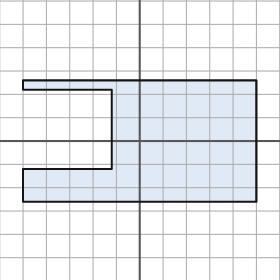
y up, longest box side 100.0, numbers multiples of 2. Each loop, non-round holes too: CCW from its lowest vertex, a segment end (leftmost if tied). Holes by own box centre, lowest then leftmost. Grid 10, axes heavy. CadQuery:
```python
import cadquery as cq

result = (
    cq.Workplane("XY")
    .moveTo(-50.0, -26.0)
    .lineTo(50.0, -26.0)
    .lineTo(50.0, 26.0)
    .lineTo(-50.0, 26.0)
    .lineTo(-50.0, 22.0)
    .lineTo(-12.0, 22.0)
    .lineTo(-12.0, -12.0)
    .lineTo(-50.0, -12.0)
    .close()
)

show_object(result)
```